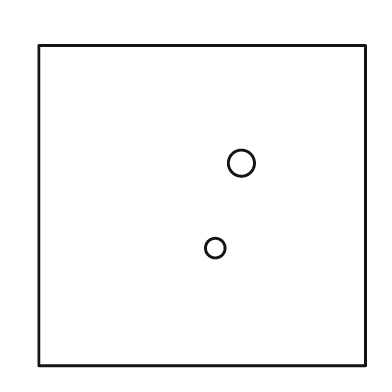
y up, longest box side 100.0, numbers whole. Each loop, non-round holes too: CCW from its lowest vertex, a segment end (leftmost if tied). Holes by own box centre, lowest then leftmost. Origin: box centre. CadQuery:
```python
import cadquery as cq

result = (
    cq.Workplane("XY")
    .moveTo(-50.0, -49.0)
    .lineTo(50.0, -49.0)
    .lineTo(50.0, 49.0)
    .lineTo(-50.0, 49.0)
    .close()
    .moveTo(4.0, -13.0)
    .circle(3.0)
    .moveTo(12.0, 13.0)
    .circle(4.0)
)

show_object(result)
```